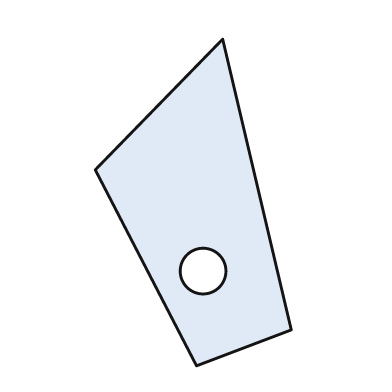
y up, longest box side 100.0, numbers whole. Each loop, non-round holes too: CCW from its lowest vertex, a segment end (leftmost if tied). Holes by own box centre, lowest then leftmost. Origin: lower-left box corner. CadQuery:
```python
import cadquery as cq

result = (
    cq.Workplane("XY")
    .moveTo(31.0, 0.0)
    .lineTo(60.0, 11.0)
    .lineTo(39.0, 100.0)
    .lineTo(0.0, 60.0)
    .close()
    .moveTo(33.0, 29.0)
    .circle(7.0)
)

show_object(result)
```